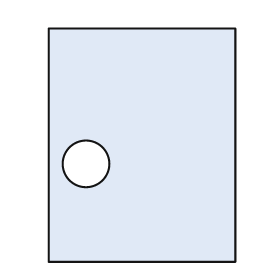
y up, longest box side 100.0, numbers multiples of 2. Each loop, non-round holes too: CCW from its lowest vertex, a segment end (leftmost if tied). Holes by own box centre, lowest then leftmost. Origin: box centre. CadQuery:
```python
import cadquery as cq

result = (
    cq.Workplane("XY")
    .moveTo(-40.0, -50.0)
    .lineTo(40.0, -50.0)
    .lineTo(40.0, 50.0)
    .lineTo(-40.0, 50.0)
    .close()
    .moveTo(-24.0, -8.0)
    .circle(10.0)
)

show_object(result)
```